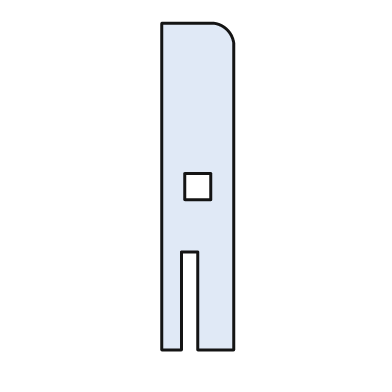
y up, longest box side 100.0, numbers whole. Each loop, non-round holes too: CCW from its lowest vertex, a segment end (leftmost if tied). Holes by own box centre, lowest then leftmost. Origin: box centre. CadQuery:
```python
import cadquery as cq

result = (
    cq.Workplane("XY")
    .moveTo(-11.0, -50.0)
    .lineTo(-5.0, -50.0)
    .lineTo(-5.0, -20.0)
    .lineTo(0.0, -20.0)
    .lineTo(0.0, -50.0)
    .lineTo(11.0, -50.0)
    .lineTo(11.0, 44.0)
    .threePointArc((9.0, 48.0), (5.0, 50.0))
    .lineTo(-11.0, 50.0)
    .close()
    .moveTo(-4.0, -4.0)
    .lineTo(4.0, -4.0)
    .lineTo(4.0, 4.0)
    .lineTo(-4.0, 4.0)
    .close()
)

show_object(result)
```